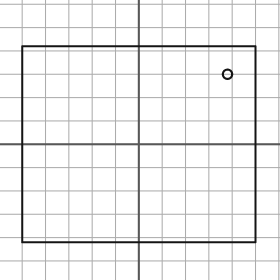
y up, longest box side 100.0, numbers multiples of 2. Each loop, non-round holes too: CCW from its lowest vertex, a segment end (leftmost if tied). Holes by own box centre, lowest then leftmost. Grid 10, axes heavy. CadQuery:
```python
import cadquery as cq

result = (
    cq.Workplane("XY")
    .moveTo(-50.0, -42.0)
    .lineTo(50.0, -42.0)
    .lineTo(50.0, 42.0)
    .lineTo(-50.0, 42.0)
    .close()
    .moveTo(38.0, 30.0)
    .circle(2.0)
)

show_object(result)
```